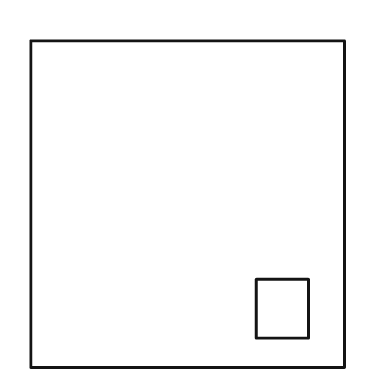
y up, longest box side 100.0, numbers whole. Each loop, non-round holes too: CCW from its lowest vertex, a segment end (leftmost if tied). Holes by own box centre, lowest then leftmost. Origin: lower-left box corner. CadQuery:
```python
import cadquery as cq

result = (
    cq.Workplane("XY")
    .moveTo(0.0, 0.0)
    .lineTo(96.0, 0.0)
    .lineTo(96.0, 100.0)
    .lineTo(0.0, 100.0)
    .close()
    .moveTo(69.0, 9.0)
    .lineTo(85.0, 9.0)
    .lineTo(85.0, 27.0)
    .lineTo(69.0, 27.0)
    .close()
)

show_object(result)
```